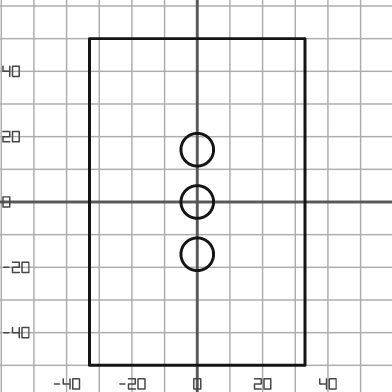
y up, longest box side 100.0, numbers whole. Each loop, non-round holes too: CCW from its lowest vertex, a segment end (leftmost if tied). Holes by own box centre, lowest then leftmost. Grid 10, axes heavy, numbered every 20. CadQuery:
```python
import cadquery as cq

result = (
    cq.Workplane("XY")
    .moveTo(-33.0, -50.0)
    .lineTo(33.0, -50.0)
    .lineTo(33.0, 50.0)
    .lineTo(-33.0, 50.0)
    .close()
    .moveTo(0.0, -16.0)
    .circle(5.0)
    .moveTo(0.0, 0.0)
    .circle(5.0)
    .moveTo(0.0, 16.0)
    .circle(5.0)
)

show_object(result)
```